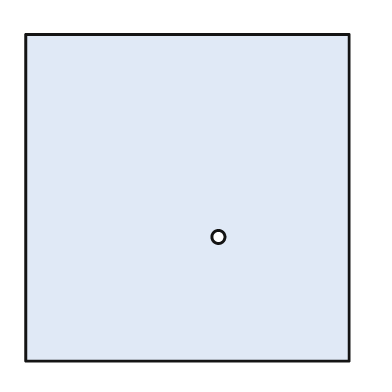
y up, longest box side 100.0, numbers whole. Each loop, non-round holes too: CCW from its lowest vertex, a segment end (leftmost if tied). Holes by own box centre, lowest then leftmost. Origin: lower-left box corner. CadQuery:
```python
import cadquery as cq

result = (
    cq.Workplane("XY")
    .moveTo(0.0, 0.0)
    .lineTo(99.0, 0.0)
    .lineTo(99.0, 100.0)
    .lineTo(0.0, 100.0)
    .close()
    .moveTo(59.0, 38.0)
    .circle(2.0)
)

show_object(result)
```